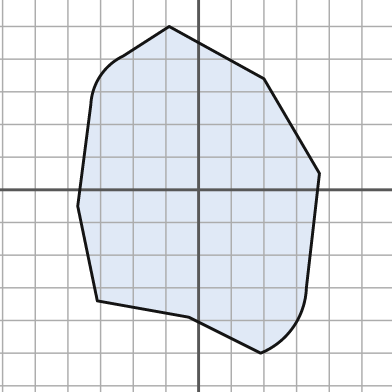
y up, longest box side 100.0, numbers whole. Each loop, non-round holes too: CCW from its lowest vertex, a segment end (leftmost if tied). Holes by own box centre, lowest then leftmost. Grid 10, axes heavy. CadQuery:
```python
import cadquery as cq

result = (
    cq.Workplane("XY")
    .moveTo(19.0, -50.0)
    .threePointArc((29.0, -42.0), (33.0, -30.0))
    .lineTo(37.0, 5.0)
    .lineTo(20.0, 34.0)
    .lineTo(-9.0, 50.0)
    .lineTo(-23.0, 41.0)
    .threePointArc((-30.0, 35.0), (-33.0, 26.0))
    .lineTo(-37.0, -5.0)
    .lineTo(-31.0, -34.0)
    .lineTo(-3.0, -39.0)
    .close()
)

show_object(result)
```